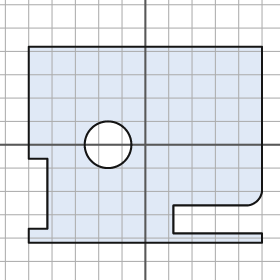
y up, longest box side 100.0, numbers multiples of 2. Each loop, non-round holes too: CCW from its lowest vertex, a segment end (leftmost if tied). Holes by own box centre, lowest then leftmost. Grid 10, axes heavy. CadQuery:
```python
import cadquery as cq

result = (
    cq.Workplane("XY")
    .moveTo(-50.0, -42.0)
    .lineTo(50.0, -42.0)
    .lineTo(50.0, -38.0)
    .lineTo(12.0, -38.0)
    .lineTo(12.0, -26.0)
    .lineTo(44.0, -26.0)
    .threePointArc((48.0, -24.0), (50.0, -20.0))
    .lineTo(50.0, 42.0)
    .lineTo(-50.0, 42.0)
    .lineTo(-50.0, -6.0)
    .lineTo(-42.0, -6.0)
    .lineTo(-42.0, -36.0)
    .lineTo(-50.0, -36.0)
    .close()
    .moveTo(-16.0, 0.0)
    .circle(10.0)
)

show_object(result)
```